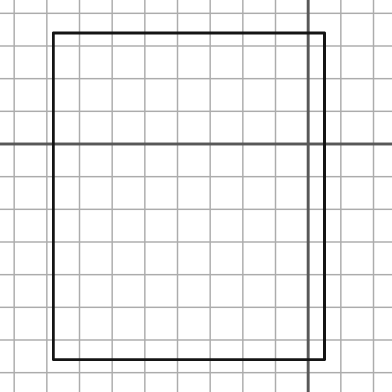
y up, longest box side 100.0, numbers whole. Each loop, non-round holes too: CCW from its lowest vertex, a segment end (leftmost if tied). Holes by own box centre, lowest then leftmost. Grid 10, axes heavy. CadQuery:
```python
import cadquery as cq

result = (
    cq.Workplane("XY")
    .moveTo(-78.0, -66.0)
    .lineTo(5.0, -66.0)
    .lineTo(5.0, 34.0)
    .lineTo(-78.0, 34.0)
    .close()
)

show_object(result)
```